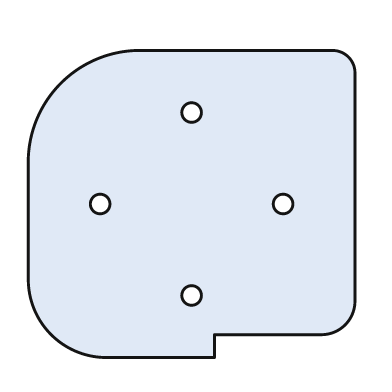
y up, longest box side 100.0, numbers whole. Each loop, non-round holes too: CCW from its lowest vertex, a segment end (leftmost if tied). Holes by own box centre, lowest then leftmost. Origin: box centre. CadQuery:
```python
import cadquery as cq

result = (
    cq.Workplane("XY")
    .moveTo(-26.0, -47.0)
    .lineTo(7.0, -47.0)
    .lineTo(7.0, -40.0)
    .lineTo(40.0, -40.0)
    .threePointArc((47.0, -37.0), (50.0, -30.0))
    .lineTo(50.0, 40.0)
    .threePointArc((48.0, 45.0), (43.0, 47.0))
    .lineTo(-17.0, 47.0)
    .threePointArc((-40.0, 37.0), (-50.0, 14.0))
    .lineTo(-50.0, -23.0)
    .threePointArc((-43.0, -40.0), (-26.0, -47.0))
    .close()
    .moveTo(0.0, -28.0)
    .circle(3.0)
    .moveTo(-28.0, 0.0)
    .circle(3.0)
    .moveTo(28.0, 0.0)
    .circle(3.0)
    .moveTo(0.0, 28.0)
    .circle(3.0)
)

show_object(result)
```